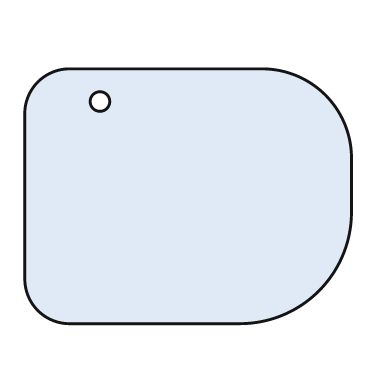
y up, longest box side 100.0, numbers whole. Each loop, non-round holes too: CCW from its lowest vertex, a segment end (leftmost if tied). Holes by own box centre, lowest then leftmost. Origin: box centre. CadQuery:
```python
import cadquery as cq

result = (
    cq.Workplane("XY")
    .moveTo(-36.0, -39.0)
    .lineTo(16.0, -39.0)
    .threePointArc((40.0, -29.0), (50.0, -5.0))
    .lineTo(50.0, 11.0)
    .threePointArc((42.0, 31.0), (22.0, 39.0))
    .lineTo(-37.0, 39.0)
    .threePointArc((-46.0, 35.0), (-50.0, 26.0))
    .lineTo(-50.0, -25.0)
    .threePointArc((-46.0, -35.0), (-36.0, -39.0))
    .close()
    .moveTo(-27.0, 29.0)
    .circle(3.0)
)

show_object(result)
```